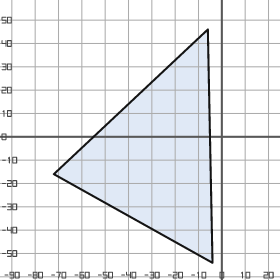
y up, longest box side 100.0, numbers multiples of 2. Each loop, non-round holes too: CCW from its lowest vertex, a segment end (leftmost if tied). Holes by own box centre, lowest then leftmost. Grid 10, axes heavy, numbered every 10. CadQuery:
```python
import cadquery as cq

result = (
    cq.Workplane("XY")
    .moveTo(-4.0, -54.0)
    .lineTo(-6.0, 46.0)
    .lineTo(-72.0, -16.0)
    .close()
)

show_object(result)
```